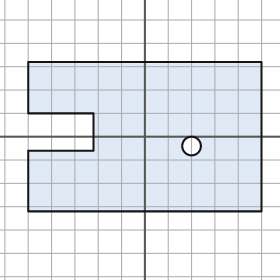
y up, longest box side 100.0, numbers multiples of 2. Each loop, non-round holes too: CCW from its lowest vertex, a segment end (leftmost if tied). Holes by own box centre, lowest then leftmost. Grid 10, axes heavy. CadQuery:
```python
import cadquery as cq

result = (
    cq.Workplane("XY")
    .moveTo(-50.0, -32.0)
    .lineTo(50.0, -32.0)
    .lineTo(50.0, 32.0)
    .lineTo(-50.0, 32.0)
    .lineTo(-50.0, 10.0)
    .lineTo(-22.0, 10.0)
    .lineTo(-22.0, -6.0)
    .lineTo(-50.0, -6.0)
    .close()
    .moveTo(20.0, -4.0)
    .circle(4.0)
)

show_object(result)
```